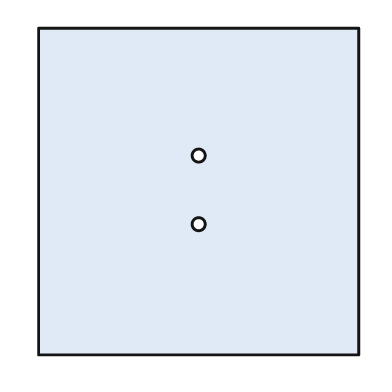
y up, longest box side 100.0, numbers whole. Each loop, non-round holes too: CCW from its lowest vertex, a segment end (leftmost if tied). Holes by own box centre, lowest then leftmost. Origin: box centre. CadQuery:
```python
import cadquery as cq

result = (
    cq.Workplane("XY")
    .moveTo(-49.0, -50.0)
    .lineTo(49.0, -50.0)
    .lineTo(49.0, 50.0)
    .lineTo(-49.0, 50.0)
    .close()
    .moveTo(0.0, -10.0)
    .circle(2.0)
    .moveTo(0.0, 11.0)
    .circle(2.0)
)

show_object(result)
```